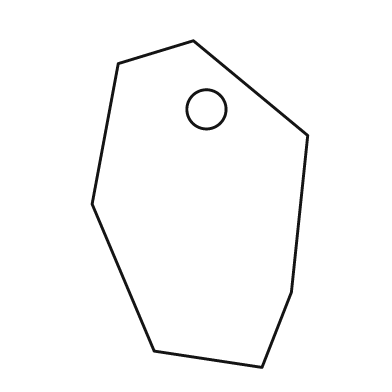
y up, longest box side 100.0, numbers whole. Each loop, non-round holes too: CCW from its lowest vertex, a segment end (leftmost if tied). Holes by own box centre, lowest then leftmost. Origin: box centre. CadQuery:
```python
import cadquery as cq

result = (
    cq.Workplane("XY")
    .moveTo(19.0, -50.0)
    .lineTo(28.0, -27.0)
    .lineTo(33.0, 21.0)
    .lineTo(-2.0, 50.0)
    .lineTo(-25.0, 43.0)
    .lineTo(-33.0, 0.0)
    .lineTo(-14.0, -45.0)
    .close()
    .moveTo(2.0, 29.0)
    .circle(6.0)
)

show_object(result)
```